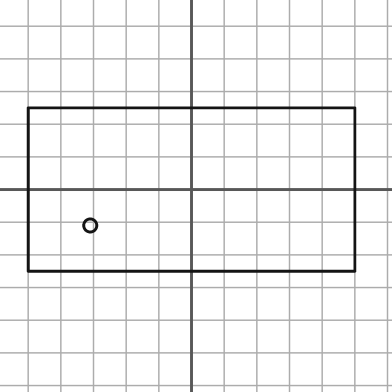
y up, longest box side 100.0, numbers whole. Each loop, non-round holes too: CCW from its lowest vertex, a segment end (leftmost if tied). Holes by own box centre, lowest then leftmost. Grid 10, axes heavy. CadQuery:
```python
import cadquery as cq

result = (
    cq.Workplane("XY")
    .moveTo(-50.0, -25.0)
    .lineTo(50.0, -25.0)
    .lineTo(50.0, 25.0)
    .lineTo(-50.0, 25.0)
    .close()
    .moveTo(-31.0, -11.0)
    .circle(2.0)
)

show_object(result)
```